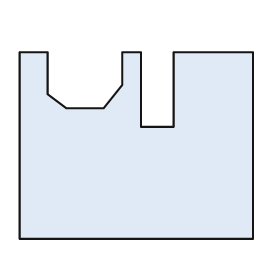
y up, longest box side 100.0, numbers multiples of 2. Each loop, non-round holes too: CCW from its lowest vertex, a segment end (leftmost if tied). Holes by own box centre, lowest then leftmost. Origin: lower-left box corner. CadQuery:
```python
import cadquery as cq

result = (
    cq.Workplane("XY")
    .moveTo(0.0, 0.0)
    .lineTo(100.0, 0.0)
    .lineTo(100.0, 80.0)
    .lineTo(66.0, 80.0)
    .lineTo(66.0, 48.0)
    .lineTo(52.0, 48.0)
    .lineTo(52.0, 80.0)
    .lineTo(44.0, 80.0)
    .lineTo(44.0, 66.0)
    .lineTo(36.0, 56.0)
    .lineTo(20.0, 56.0)
    .lineTo(12.0, 62.0)
    .lineTo(12.0, 80.0)
    .lineTo(0.0, 80.0)
    .close()
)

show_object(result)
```